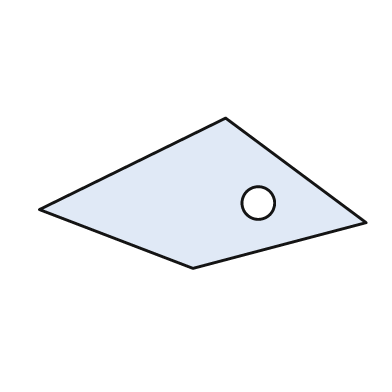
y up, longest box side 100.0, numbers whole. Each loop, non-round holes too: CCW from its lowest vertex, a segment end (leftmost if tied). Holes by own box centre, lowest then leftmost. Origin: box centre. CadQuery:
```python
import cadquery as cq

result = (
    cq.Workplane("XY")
    .moveTo(-3.0, -23.0)
    .lineTo(50.0, -9.0)
    .lineTo(7.0, 23.0)
    .lineTo(-50.0, -5.0)
    .close()
    .moveTo(17.0, -3.0)
    .circle(5.0)
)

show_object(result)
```